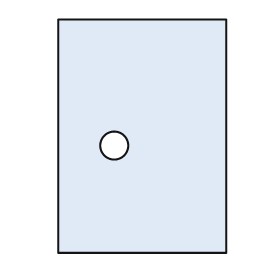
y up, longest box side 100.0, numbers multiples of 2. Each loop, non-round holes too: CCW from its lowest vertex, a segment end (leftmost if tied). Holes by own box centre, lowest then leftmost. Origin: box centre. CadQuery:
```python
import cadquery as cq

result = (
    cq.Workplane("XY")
    .moveTo(-36.0, -50.0)
    .lineTo(36.0, -50.0)
    .lineTo(36.0, 50.0)
    .lineTo(-36.0, 50.0)
    .close()
    .moveTo(-12.0, -4.0)
    .circle(6.0)
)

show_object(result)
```